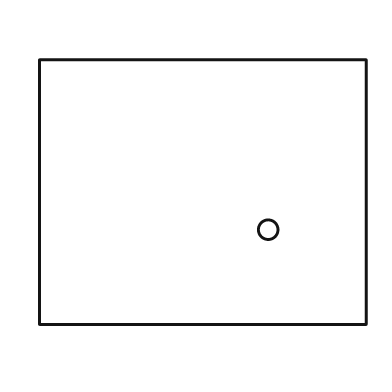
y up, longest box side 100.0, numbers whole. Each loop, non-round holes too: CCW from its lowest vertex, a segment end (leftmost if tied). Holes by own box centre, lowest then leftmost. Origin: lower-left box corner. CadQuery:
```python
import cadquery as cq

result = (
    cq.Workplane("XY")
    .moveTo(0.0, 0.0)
    .lineTo(100.0, 0.0)
    .lineTo(100.0, 81.0)
    .lineTo(0.0, 81.0)
    .close()
    .moveTo(70.0, 29.0)
    .circle(3.0)
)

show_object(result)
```